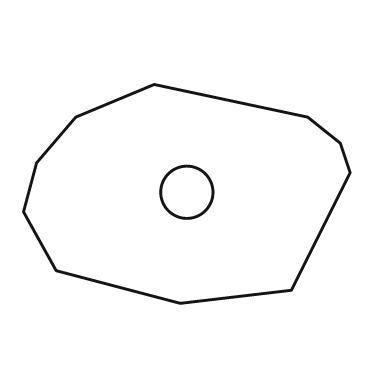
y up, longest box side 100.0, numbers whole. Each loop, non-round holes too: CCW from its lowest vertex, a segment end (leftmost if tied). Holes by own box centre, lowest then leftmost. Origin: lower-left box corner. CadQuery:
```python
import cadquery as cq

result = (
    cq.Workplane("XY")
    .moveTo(48.0, 0.0)
    .lineTo(82.0, 4.0)
    .lineTo(100.0, 40.0)
    .lineTo(97.0, 49.0)
    .lineTo(87.0, 57.0)
    .lineTo(40.0, 67.0)
    .lineTo(16.0, 57.0)
    .lineTo(4.0, 43.0)
    .lineTo(0.0, 28.0)
    .lineTo(10.0, 10.0)
    .close()
    .moveTo(50.0, 34.0)
    .circle(8.0)
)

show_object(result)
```